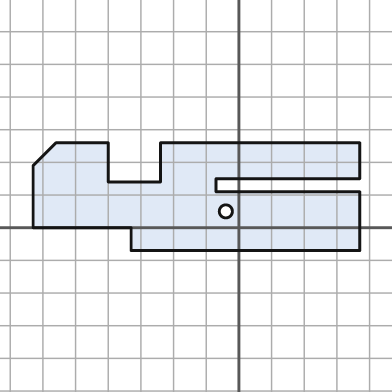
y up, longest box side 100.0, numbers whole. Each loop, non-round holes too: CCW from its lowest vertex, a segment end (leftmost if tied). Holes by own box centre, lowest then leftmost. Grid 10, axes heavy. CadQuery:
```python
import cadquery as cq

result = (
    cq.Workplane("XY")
    .moveTo(-33.0, -7.0)
    .lineTo(37.0, -7.0)
    .lineTo(37.0, 11.0)
    .lineTo(-7.0, 11.0)
    .lineTo(-7.0, 15.0)
    .lineTo(37.0, 15.0)
    .lineTo(37.0, 26.0)
    .lineTo(-24.0, 26.0)
    .lineTo(-24.0, 14.0)
    .lineTo(-40.0, 14.0)
    .lineTo(-40.0, 26.0)
    .lineTo(-56.0, 26.0)
    .lineTo(-63.0, 19.0)
    .lineTo(-63.0, 0.0)
    .lineTo(-33.0, 0.0)
    .close()
    .moveTo(-4.0, 5.0)
    .circle(2.0)
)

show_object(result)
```